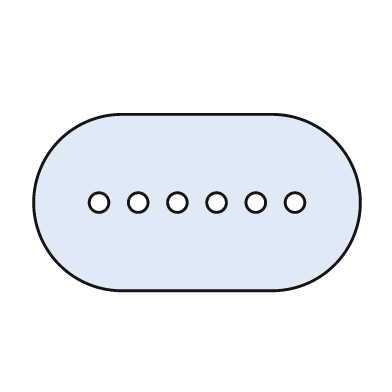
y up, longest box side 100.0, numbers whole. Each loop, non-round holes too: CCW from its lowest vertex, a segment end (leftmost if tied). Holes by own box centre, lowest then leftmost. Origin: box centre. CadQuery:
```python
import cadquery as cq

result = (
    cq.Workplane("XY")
    .moveTo(-23.0, -27.0)
    .lineTo(23.0, -27.0)
    .threePointArc((50.0, 0.0), (23.0, 27.0))
    .lineTo(-23.0, 27.0)
    .threePointArc((-50.0, 0.0), (-23.0, -27.0))
    .close()
    .moveTo(-30.0, 0.0)
    .circle(3.0)
    .moveTo(-18.0, 0.0)
    .circle(3.0)
    .moveTo(-6.0, 0.0)
    .circle(3.0)
    .moveTo(6.0, 0.0)
    .circle(3.0)
    .moveTo(18.0, 0.0)
    .circle(3.0)
    .moveTo(30.0, 0.0)
    .circle(3.0)
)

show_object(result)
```